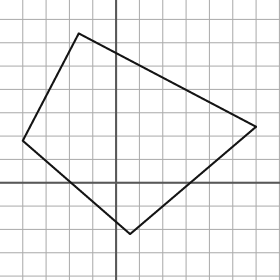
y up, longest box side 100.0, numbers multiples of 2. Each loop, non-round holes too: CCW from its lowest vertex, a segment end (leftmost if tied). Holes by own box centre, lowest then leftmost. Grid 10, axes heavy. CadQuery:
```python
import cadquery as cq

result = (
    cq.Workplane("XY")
    .moveTo(6.0, -22.0)
    .lineTo(60.0, 24.0)
    .lineTo(-16.0, 64.0)
    .lineTo(-40.0, 18.0)
    .close()
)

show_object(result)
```